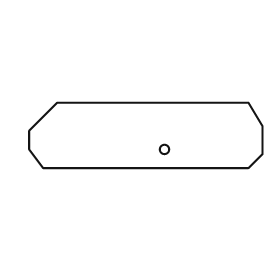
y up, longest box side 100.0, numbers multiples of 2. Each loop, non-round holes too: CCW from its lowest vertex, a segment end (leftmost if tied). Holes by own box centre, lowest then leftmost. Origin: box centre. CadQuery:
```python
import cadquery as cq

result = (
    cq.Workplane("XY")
    .moveTo(-44.0, -14.0)
    .lineTo(44.0, -14.0)
    .lineTo(50.0, -8.0)
    .lineTo(50.0, 4.0)
    .lineTo(44.0, 14.0)
    .lineTo(-38.0, 14.0)
    .lineTo(-50.0, 2.0)
    .lineTo(-50.0, -6.0)
    .close()
    .moveTo(8.0, -6.0)
    .circle(2.0)
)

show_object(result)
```